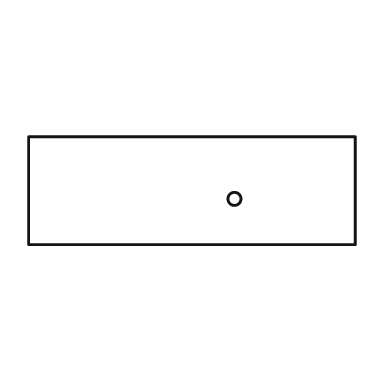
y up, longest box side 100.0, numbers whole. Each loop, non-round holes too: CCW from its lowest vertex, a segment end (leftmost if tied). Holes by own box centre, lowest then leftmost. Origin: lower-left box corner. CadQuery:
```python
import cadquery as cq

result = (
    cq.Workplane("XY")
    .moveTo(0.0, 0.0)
    .lineTo(100.0, 0.0)
    .lineTo(100.0, 33.0)
    .lineTo(0.0, 33.0)
    .close()
    .moveTo(63.0, 14.0)
    .circle(2.0)
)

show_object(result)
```